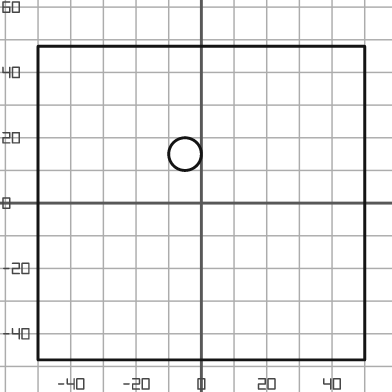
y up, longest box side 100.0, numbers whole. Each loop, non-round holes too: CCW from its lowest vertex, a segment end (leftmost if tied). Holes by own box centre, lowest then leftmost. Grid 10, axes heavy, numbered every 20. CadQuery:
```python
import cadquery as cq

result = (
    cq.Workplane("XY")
    .moveTo(-50.0, -48.0)
    .lineTo(50.0, -48.0)
    .lineTo(50.0, 48.0)
    .lineTo(-50.0, 48.0)
    .close()
    .moveTo(-5.0, 15.0)
    .circle(5.0)
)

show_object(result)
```